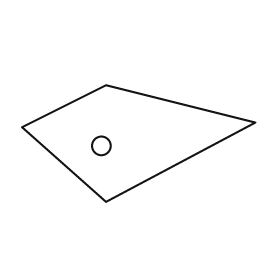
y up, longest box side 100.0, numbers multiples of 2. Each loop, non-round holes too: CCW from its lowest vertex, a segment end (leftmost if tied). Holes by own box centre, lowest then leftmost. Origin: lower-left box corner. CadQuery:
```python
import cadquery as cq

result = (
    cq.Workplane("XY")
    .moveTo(36.0, 0.0)
    .lineTo(100.0, 34.0)
    .lineTo(36.0, 50.0)
    .lineTo(0.0, 32.0)
    .close()
    .moveTo(34.0, 24.0)
    .circle(4.0)
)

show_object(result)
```